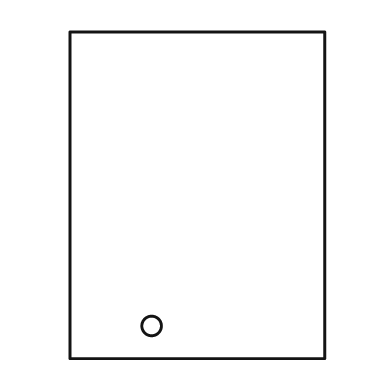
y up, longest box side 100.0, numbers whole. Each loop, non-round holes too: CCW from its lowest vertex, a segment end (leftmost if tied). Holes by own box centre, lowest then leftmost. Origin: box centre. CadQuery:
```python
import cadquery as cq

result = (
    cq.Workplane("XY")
    .moveTo(-39.0, -50.0)
    .lineTo(39.0, -50.0)
    .lineTo(39.0, 50.0)
    .lineTo(-39.0, 50.0)
    .close()
    .moveTo(-14.0, -40.0)
    .circle(3.0)
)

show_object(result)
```